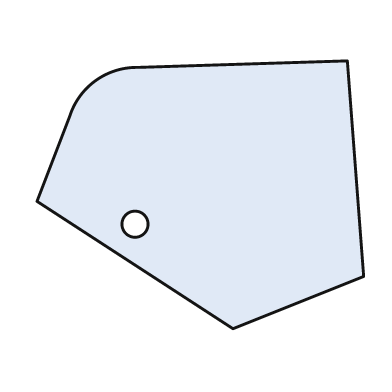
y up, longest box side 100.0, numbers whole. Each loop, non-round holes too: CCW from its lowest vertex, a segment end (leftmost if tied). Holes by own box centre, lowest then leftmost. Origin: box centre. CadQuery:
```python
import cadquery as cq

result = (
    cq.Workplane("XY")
    .moveTo(10.0, -41.0)
    .lineTo(50.0, -25.0)
    .lineTo(45.0, 41.0)
    .lineTo(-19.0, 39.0)
    .threePointArc((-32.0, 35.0), (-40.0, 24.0))
    .lineTo(-50.0, -2.0)
    .close()
    .moveTo(-20.0, -9.0)
    .circle(4.0)
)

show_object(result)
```